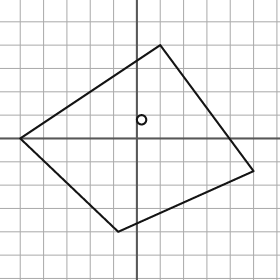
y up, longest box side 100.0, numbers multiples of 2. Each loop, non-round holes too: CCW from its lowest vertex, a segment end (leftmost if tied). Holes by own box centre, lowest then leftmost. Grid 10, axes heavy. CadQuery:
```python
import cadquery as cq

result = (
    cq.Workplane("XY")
    .moveTo(-8.0, -40.0)
    .lineTo(50.0, -14.0)
    .lineTo(10.0, 40.0)
    .lineTo(-50.0, 0.0)
    .close()
    .moveTo(2.0, 8.0)
    .circle(2.0)
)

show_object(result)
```